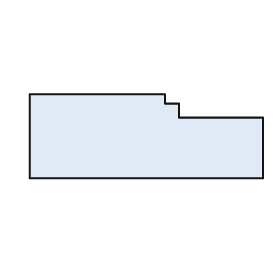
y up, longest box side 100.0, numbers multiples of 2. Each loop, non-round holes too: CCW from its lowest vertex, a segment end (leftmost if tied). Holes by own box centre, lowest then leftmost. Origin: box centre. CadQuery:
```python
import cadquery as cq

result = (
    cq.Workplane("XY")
    .moveTo(-50.0, -18.0)
    .lineTo(50.0, -18.0)
    .lineTo(50.0, 8.0)
    .lineTo(14.0, 8.0)
    .lineTo(14.0, 14.0)
    .lineTo(8.0, 14.0)
    .lineTo(8.0, 18.0)
    .lineTo(-50.0, 18.0)
    .close()
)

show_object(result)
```